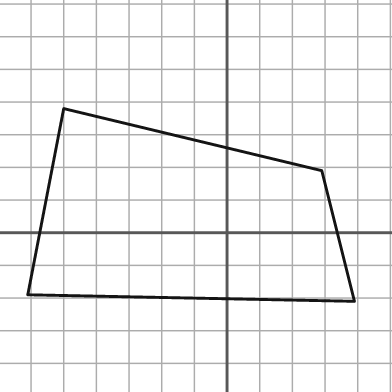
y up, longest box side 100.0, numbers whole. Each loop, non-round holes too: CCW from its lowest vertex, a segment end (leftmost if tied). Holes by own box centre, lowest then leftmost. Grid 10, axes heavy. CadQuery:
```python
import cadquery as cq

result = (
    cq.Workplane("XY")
    .moveTo(39.0, -21.0)
    .lineTo(29.0, 19.0)
    .lineTo(-50.0, 38.0)
    .lineTo(-61.0, -19.0)
    .close()
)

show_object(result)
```